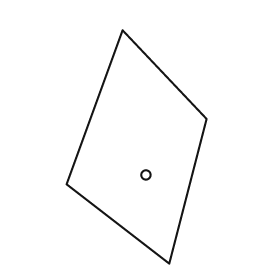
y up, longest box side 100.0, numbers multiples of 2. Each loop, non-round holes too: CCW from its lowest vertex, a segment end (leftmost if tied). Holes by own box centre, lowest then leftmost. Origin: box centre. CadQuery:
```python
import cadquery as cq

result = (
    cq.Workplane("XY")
    .moveTo(14.0, -50.0)
    .lineTo(30.0, 12.0)
    .lineTo(-6.0, 50.0)
    .lineTo(-30.0, -16.0)
    .close()
    .moveTo(4.0, -12.0)
    .circle(2.0)
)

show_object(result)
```